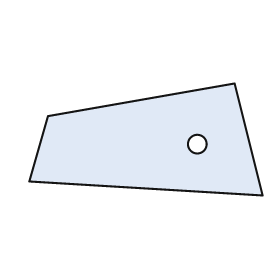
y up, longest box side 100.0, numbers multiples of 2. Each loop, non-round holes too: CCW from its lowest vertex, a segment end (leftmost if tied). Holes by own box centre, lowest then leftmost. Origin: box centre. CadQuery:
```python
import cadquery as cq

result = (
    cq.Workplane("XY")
    .moveTo(50.0, -24.0)
    .lineTo(38.0, 24.0)
    .lineTo(-42.0, 10.0)
    .lineTo(-50.0, -18.0)
    .close()
    .moveTo(22.0, -2.0)
    .circle(4.0)
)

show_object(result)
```